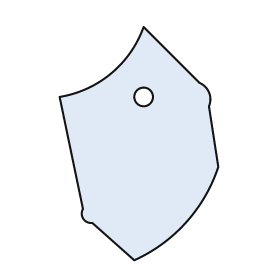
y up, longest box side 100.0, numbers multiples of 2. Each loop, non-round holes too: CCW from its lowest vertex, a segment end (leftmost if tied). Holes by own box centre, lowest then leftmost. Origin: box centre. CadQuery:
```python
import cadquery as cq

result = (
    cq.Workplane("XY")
    .moveTo(-2.0, -50.0)
    .threePointArc((20.0, -34.0), (34.0, -10.0))
    .lineTo(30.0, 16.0)
    .threePointArc((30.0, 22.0), (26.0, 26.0))
    .lineTo(2.0, 50.0)
    .threePointArc((-12.0, 30.0), (-34.0, 20.0))
    .lineTo(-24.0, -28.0)
    .threePointArc((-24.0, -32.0), (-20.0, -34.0))
    .close()
    .moveTo(2.0, 20.0)
    .circle(4.0)
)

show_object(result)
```